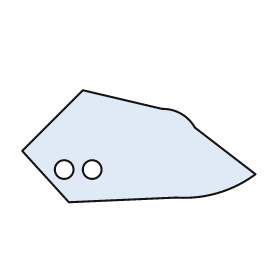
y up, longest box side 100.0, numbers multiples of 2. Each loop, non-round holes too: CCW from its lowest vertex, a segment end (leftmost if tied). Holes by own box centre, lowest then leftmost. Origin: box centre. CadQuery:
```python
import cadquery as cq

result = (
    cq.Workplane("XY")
    .moveTo(-30.0, -24.0)
    .lineTo(16.0, -22.0)
    .threePointArc((34.0, -20.0), (50.0, -12.0))
    .lineTo(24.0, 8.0)
    .threePointArc((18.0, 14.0), (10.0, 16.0))
    .lineTo(-24.0, 24.0)
    .lineTo(-50.0, -2.0)
    .close()
    .moveTo(-32.0, -10.0)
    .circle(4.0)
    .moveTo(-20.0, -10.0)
    .circle(4.0)
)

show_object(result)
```